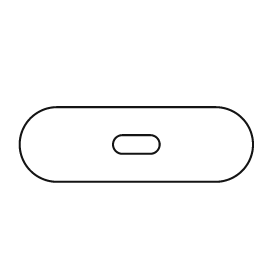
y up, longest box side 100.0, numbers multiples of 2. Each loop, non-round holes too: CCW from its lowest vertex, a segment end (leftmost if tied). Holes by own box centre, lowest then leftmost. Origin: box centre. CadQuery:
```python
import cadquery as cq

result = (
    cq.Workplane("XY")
    .moveTo(-34.0, -16.0)
    .lineTo(34.0, -16.0)
    .threePointArc((50.0, 0.0), (34.0, 16.0))
    .lineTo(-34.0, 16.0)
    .threePointArc((-50.0, 0.0), (-34.0, -16.0))
    .close()
    .moveTo(-6.0, -4.0)
    .lineTo(6.0, -4.0)
    .threePointArc((10.0, 0.0), (6.0, 4.0))
    .lineTo(-6.0, 4.0)
    .threePointArc((-10.0, 0.0), (-6.0, -4.0))
    .close()
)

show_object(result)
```